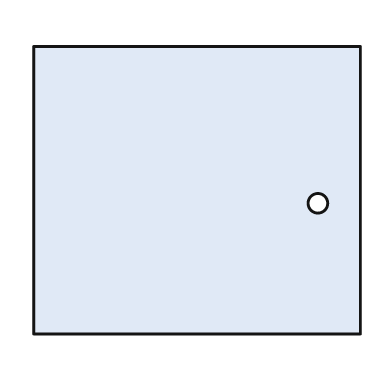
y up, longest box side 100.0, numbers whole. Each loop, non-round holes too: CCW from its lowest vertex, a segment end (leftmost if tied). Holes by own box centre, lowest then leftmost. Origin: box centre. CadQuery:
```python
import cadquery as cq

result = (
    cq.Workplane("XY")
    .moveTo(-50.0, -44.0)
    .lineTo(50.0, -44.0)
    .lineTo(50.0, 44.0)
    .lineTo(-50.0, 44.0)
    .close()
    .moveTo(37.0, -4.0)
    .circle(3.0)
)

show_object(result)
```